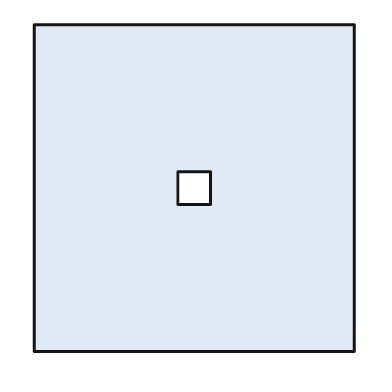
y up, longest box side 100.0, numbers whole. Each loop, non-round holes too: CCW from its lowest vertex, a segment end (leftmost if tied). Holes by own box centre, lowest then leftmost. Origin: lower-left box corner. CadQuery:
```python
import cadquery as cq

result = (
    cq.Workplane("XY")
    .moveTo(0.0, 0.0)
    .lineTo(98.0, 0.0)
    .lineTo(98.0, 100.0)
    .lineTo(0.0, 100.0)
    .close()
    .moveTo(44.0, 45.0)
    .lineTo(54.0, 45.0)
    .lineTo(54.0, 55.0)
    .lineTo(44.0, 55.0)
    .close()
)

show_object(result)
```